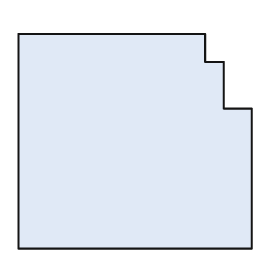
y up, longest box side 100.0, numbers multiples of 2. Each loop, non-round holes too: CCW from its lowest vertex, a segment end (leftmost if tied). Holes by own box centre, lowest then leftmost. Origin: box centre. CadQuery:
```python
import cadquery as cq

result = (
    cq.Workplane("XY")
    .moveTo(-50.0, -46.0)
    .lineTo(50.0, -46.0)
    .lineTo(50.0, 14.0)
    .lineTo(38.0, 14.0)
    .lineTo(38.0, 34.0)
    .lineTo(30.0, 34.0)
    .lineTo(30.0, 46.0)
    .lineTo(-50.0, 46.0)
    .close()
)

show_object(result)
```